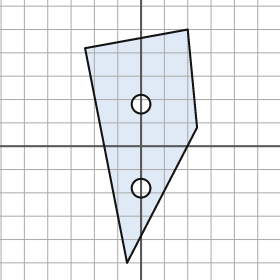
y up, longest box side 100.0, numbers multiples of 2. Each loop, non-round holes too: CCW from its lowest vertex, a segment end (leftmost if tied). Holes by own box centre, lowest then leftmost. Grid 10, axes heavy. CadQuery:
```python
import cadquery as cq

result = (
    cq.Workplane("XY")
    .moveTo(-6.0, -50.0)
    .lineTo(24.0, 8.0)
    .lineTo(20.0, 50.0)
    .lineTo(-24.0, 42.0)
    .close()
    .moveTo(0.0, -18.0)
    .circle(4.0)
    .moveTo(0.0, 18.0)
    .circle(4.0)
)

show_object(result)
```